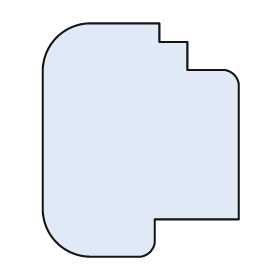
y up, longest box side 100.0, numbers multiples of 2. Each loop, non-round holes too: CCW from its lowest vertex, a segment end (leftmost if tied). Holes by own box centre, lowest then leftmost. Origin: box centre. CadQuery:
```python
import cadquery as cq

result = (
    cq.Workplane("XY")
    .moveTo(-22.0, -50.0)
    .lineTo(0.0, -50.0)
    .threePointArc((4.0, -48.0), (6.0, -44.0))
    .lineTo(6.0, -34.0)
    .lineTo(42.0, -34.0)
    .lineTo(42.0, 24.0)
    .threePointArc((40.0, 28.0), (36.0, 30.0))
    .lineTo(20.0, 30.0)
    .lineTo(20.0, 42.0)
    .lineTo(8.0, 42.0)
    .lineTo(8.0, 50.0)
    .lineTo(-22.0, 50.0)
    .threePointArc((-36.0, 44.0), (-42.0, 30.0))
    .lineTo(-42.0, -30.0)
    .threePointArc((-36.0, -44.0), (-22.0, -50.0))
    .close()
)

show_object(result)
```